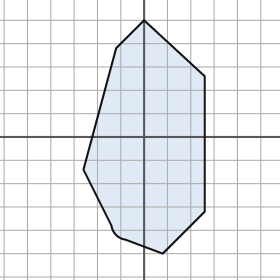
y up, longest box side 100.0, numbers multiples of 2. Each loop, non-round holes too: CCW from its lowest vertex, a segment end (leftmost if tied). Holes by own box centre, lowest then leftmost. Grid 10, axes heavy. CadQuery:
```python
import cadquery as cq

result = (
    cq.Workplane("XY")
    .moveTo(8.0, -50.0)
    .lineTo(26.0, -32.0)
    .lineTo(26.0, 26.0)
    .lineTo(0.0, 50.0)
    .lineTo(-12.0, 38.0)
    .lineTo(-26.0, -14.0)
    .lineTo(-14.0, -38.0)
    .threePointArc((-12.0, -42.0), (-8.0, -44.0))
    .close()
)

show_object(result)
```